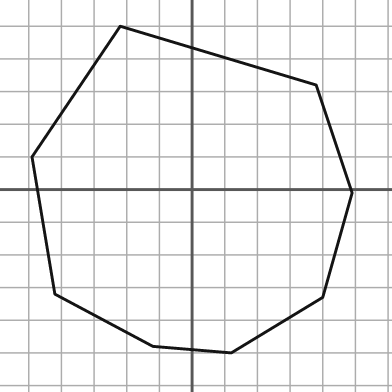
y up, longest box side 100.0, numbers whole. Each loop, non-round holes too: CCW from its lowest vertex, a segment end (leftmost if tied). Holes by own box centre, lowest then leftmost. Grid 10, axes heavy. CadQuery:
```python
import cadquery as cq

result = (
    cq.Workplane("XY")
    .moveTo(12.0, -50.0)
    .lineTo(40.0, -33.0)
    .lineTo(49.0, -1.0)
    .lineTo(38.0, 32.0)
    .lineTo(-22.0, 50.0)
    .lineTo(-49.0, 10.0)
    .lineTo(-42.0, -32.0)
    .lineTo(-12.0, -48.0)
    .close()
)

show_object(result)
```